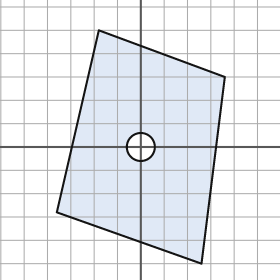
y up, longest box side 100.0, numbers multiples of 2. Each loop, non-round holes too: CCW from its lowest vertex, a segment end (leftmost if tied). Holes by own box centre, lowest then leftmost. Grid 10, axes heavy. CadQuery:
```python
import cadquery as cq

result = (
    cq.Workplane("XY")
    .moveTo(26.0, -50.0)
    .lineTo(36.0, 30.0)
    .lineTo(-18.0, 50.0)
    .lineTo(-36.0, -28.0)
    .close()
    .moveTo(0.0, 0.0)
    .circle(6.0)
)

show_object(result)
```